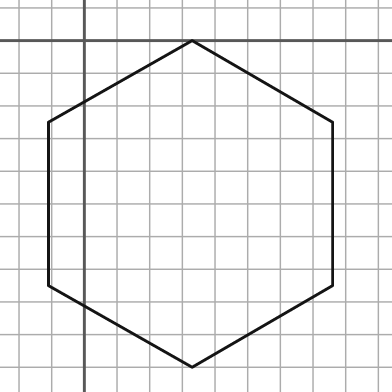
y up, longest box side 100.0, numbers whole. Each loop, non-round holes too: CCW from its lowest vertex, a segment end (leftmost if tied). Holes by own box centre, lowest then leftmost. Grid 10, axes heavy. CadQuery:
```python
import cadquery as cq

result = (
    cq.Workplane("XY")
    .moveTo(33.0, -100.0)
    .lineTo(76.0, -75.0)
    .lineTo(76.0, -25.0)
    .lineTo(33.0, 0.0)
    .lineTo(-11.0, -25.0)
    .lineTo(-11.0, -75.0)
    .close()
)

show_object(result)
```